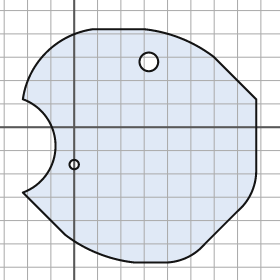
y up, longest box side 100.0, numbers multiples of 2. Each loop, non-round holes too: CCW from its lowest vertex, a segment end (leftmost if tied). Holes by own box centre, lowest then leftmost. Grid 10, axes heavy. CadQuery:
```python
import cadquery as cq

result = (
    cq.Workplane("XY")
    .moveTo(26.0, -58.0)
    .lineTo(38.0, -58.0)
    .threePointArc((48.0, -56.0), (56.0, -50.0))
    .lineTo(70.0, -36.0)
    .threePointArc((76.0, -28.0), (78.0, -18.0))
    .lineTo(78.0, 12.0)
    .lineTo(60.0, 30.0)
    .threePointArc((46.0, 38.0), (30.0, 42.0))
    .lineTo(8.0, 42.0)
    .threePointArc((-12.0, 32.0), (-22.0, 12.0))
    .threePointArc((-8.0, -8.0), (-22.0, -28.0))
    .lineTo(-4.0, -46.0)
    .threePointArc((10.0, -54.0), (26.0, -58.0))
    .close()
    .moveTo(0.0, -16.0)
    .circle(2.0)
    .moveTo(32.0, 28.0)
    .circle(4.0)
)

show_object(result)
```